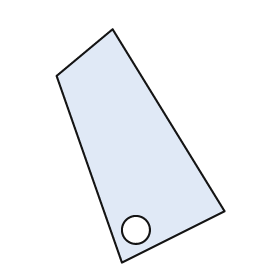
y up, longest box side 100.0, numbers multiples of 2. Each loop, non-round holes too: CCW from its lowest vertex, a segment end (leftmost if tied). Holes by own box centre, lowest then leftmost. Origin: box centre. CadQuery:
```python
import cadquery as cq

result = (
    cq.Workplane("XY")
    .moveTo(-8.0, -50.0)
    .lineTo(36.0, -28.0)
    .lineTo(-12.0, 50.0)
    .lineTo(-36.0, 30.0)
    .close()
    .moveTo(-2.0, -36.0)
    .circle(6.0)
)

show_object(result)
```